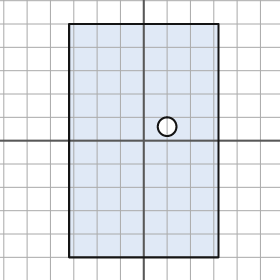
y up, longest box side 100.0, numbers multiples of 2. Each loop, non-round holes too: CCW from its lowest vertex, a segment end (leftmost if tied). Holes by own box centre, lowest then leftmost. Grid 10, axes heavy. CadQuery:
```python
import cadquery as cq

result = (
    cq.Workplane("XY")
    .moveTo(-32.0, -50.0)
    .lineTo(32.0, -50.0)
    .lineTo(32.0, 50.0)
    .lineTo(-32.0, 50.0)
    .close()
    .moveTo(10.0, 6.0)
    .circle(4.0)
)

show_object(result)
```